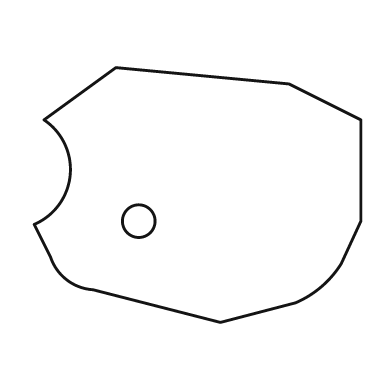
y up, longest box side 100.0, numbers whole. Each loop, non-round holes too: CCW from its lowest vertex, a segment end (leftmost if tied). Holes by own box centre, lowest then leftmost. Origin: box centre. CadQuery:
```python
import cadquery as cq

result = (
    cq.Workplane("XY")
    .moveTo(7.0, -39.0)
    .lineTo(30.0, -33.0)
    .threePointArc((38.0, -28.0), (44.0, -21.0))
    .lineTo(50.0, -8.0)
    .lineTo(50.0, 23.0)
    .lineTo(28.0, 34.0)
    .lineTo(-25.0, 39.0)
    .lineTo(-47.0, 23.0)
    .threePointArc((-39.0, 6.0), (-50.0, -9.0))
    .lineTo(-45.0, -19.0)
    .threePointArc((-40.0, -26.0), (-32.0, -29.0))
    .close()
    .moveTo(-18.0, -8.0)
    .circle(5.0)
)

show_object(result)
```